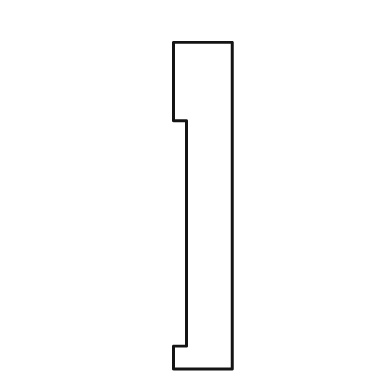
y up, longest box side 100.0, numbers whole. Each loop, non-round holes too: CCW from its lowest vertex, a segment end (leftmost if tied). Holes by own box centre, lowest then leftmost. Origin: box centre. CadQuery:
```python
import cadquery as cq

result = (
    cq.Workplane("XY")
    .moveTo(-9.0, -50.0)
    .lineTo(9.0, -50.0)
    .lineTo(9.0, 50.0)
    .lineTo(-9.0, 50.0)
    .lineTo(-9.0, 26.0)
    .lineTo(-5.0, 26.0)
    .lineTo(-5.0, -43.0)
    .lineTo(-9.0, -43.0)
    .close()
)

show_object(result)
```